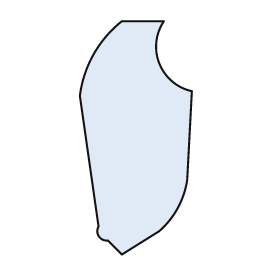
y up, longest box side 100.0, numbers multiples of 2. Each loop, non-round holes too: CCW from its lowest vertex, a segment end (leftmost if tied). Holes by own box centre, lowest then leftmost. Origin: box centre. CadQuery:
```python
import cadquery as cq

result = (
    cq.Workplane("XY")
    .moveTo(-6.0, -50.0)
    .lineTo(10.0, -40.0)
    .threePointArc((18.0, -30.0), (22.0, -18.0))
    .lineTo(24.0, 20.0)
    .threePointArc((10.0, 32.0), (12.0, 50.0))
    .lineTo(-6.0, 50.0)
    .threePointArc((-18.0, 36.0), (-24.0, 18.0))
    .lineTo(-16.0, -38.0)
    .threePointArc((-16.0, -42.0), (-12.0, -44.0))
    .close()
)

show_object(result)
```